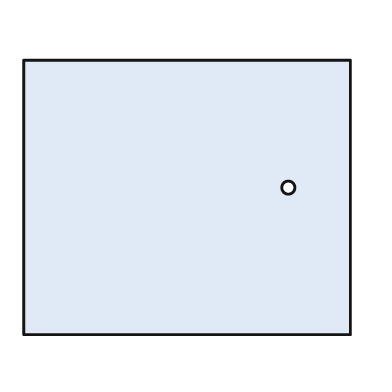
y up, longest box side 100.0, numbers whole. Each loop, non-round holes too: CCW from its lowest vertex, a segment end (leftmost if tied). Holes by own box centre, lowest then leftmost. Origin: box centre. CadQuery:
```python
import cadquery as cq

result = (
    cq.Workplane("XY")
    .moveTo(-50.0, -42.0)
    .lineTo(50.0, -42.0)
    .lineTo(50.0, 42.0)
    .lineTo(-50.0, 42.0)
    .close()
    .moveTo(31.0, 3.0)
    .circle(2.0)
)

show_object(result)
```